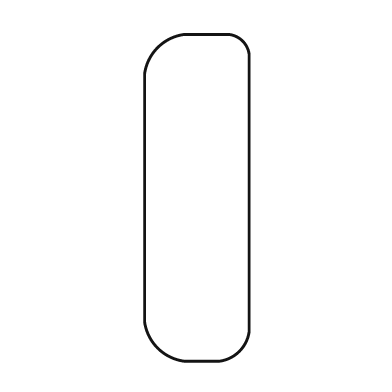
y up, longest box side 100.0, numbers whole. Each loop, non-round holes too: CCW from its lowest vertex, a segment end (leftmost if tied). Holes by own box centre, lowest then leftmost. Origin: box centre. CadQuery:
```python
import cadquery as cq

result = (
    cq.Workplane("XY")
    .moveTo(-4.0, -50.0)
    .lineTo(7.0, -50.0)
    .threePointArc((13.0, -47.0), (16.0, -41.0))
    .lineTo(16.0, 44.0)
    .threePointArc((14.0, 48.0), (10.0, 50.0))
    .lineTo(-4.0, 50.0)
    .threePointArc((-12.0, 46.0), (-16.0, 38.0))
    .lineTo(-16.0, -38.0)
    .threePointArc((-12.0, -46.0), (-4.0, -50.0))
    .close()
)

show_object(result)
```